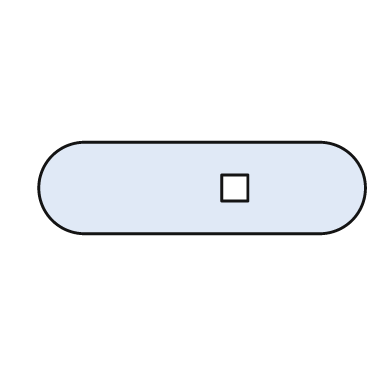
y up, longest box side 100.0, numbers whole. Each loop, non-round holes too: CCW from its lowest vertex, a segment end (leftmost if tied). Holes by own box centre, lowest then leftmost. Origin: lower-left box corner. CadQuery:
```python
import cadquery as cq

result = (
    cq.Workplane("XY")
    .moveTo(14.0, 0.0)
    .lineTo(86.0, 0.0)
    .threePointArc((100.0, 14.0), (86.0, 28.0))
    .lineTo(14.0, 28.0)
    .threePointArc((0.0, 14.0), (14.0, 0.0))
    .close()
    .moveTo(56.0, 10.0)
    .lineTo(64.0, 10.0)
    .lineTo(64.0, 18.0)
    .lineTo(56.0, 18.0)
    .close()
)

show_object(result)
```